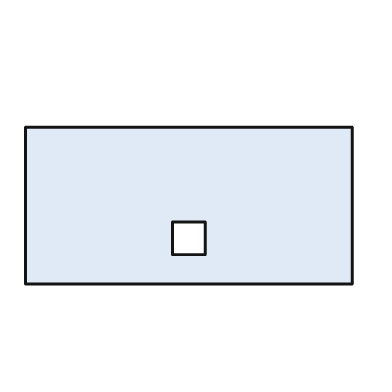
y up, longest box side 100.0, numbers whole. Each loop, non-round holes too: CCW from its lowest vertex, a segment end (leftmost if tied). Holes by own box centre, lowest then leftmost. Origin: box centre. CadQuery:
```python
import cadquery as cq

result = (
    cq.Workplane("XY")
    .moveTo(-50.0, -24.0)
    .lineTo(50.0, -24.0)
    .lineTo(50.0, 24.0)
    .lineTo(-50.0, 24.0)
    .close()
    .moveTo(-5.0, -15.0)
    .lineTo(5.0, -15.0)
    .lineTo(5.0, -5.0)
    .lineTo(-5.0, -5.0)
    .close()
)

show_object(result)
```